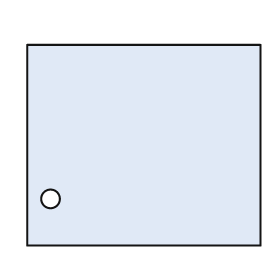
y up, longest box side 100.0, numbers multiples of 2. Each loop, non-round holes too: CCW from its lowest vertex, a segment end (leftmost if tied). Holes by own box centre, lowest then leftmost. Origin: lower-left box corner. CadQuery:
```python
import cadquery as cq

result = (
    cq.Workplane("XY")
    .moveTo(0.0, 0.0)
    .lineTo(100.0, 0.0)
    .lineTo(100.0, 86.0)
    .lineTo(0.0, 86.0)
    .close()
    .moveTo(10.0, 20.0)
    .circle(4.0)
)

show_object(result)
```